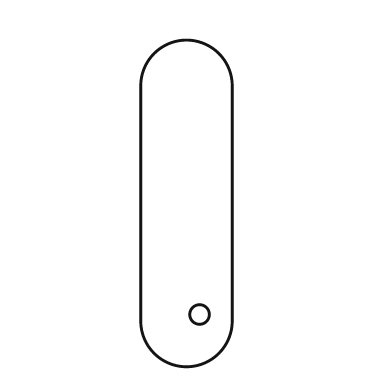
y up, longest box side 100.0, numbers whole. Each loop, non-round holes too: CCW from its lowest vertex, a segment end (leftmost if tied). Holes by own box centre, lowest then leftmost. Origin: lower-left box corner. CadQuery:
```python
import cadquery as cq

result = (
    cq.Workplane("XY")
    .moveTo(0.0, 14.0)
    .threePointArc((14.0, 0.0), (28.0, 14.0))
    .lineTo(28.0, 86.0)
    .threePointArc((14.0, 100.0), (0.0, 86.0))
    .close()
    .moveTo(18.0, 16.0)
    .circle(3.0)
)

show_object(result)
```